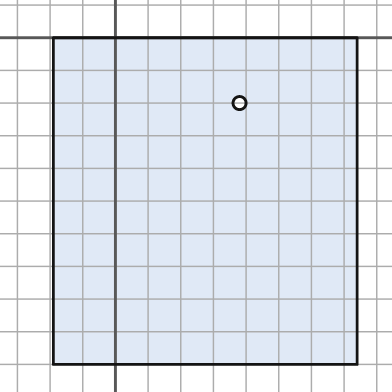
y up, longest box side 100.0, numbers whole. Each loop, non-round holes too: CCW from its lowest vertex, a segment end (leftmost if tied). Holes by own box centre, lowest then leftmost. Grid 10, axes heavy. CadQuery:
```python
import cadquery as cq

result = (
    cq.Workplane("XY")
    .moveTo(-19.0, -100.0)
    .lineTo(74.0, -100.0)
    .lineTo(74.0, 0.0)
    .lineTo(-19.0, 0.0)
    .close()
    .moveTo(38.0, -20.0)
    .circle(2.0)
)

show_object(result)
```